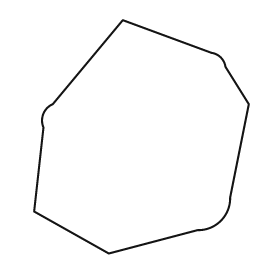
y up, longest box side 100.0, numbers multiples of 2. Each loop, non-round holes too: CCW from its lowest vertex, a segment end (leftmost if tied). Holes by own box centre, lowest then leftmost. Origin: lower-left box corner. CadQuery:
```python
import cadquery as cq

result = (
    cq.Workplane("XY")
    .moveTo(32.0, 0.0)
    .lineTo(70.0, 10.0)
    .threePointArc((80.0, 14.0), (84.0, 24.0))
    .lineTo(92.0, 64.0)
    .lineTo(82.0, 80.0)
    .threePointArc((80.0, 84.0), (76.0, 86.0))
    .lineTo(38.0, 100.0)
    .lineTo(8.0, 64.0)
    .threePointArc((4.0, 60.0), (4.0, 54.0))
    .lineTo(0.0, 18.0)
    .close()
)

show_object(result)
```